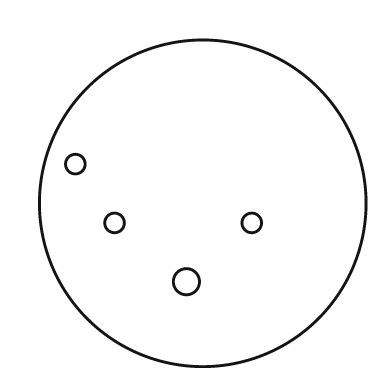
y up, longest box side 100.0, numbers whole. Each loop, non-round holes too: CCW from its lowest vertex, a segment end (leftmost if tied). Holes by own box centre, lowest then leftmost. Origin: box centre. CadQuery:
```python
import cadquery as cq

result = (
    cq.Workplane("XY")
    .moveTo(0.0, 0.0)
    .circle(50.0)
    .moveTo(-5.0, -24.0)
    .circle(4.0)
    .moveTo(-27.0, -6.0)
    .circle(3.0)
    .moveTo(15.0, -6.0)
    .circle(3.0)
    .moveTo(-39.0, 12.0)
    .circle(3.0)
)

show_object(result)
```